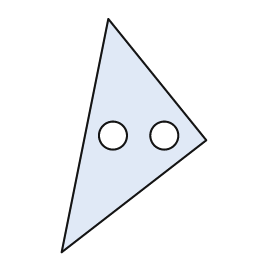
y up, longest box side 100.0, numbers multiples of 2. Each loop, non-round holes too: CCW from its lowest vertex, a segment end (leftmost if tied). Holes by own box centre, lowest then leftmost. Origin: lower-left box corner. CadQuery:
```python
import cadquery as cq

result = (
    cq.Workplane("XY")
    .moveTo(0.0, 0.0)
    .lineTo(62.0, 48.0)
    .lineTo(20.0, 100.0)
    .close()
    .moveTo(22.0, 50.0)
    .circle(6.0)
    .moveTo(44.0, 50.0)
    .circle(6.0)
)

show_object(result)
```